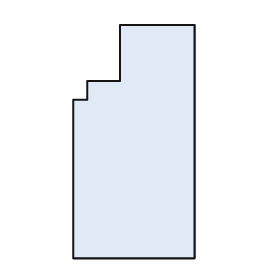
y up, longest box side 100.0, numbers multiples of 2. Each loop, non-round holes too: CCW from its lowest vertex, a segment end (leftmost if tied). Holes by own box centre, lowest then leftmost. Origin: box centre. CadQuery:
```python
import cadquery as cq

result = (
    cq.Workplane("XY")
    .moveTo(-26.0, -50.0)
    .lineTo(26.0, -50.0)
    .lineTo(26.0, 50.0)
    .lineTo(-6.0, 50.0)
    .lineTo(-6.0, 26.0)
    .lineTo(-20.0, 26.0)
    .lineTo(-20.0, 18.0)
    .lineTo(-26.0, 18.0)
    .close()
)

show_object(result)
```